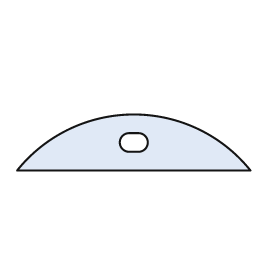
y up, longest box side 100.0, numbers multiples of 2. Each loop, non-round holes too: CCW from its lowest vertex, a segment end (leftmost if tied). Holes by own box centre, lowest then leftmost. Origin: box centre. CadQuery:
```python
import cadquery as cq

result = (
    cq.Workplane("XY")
    .moveTo(-50.0, -12.0)
    .lineTo(50.0, -12.0)
    .threePointArc((0.0, 12.0), (-50.0, -12.0))
    .close()
    .moveTo(-2.0, -4.0)
    .lineTo(2.0, -4.0)
    .threePointArc((6.0, 0.0), (2.0, 4.0))
    .lineTo(-2.0, 4.0)
    .threePointArc((-6.0, 0.0), (-2.0, -4.0))
    .close()
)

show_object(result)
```